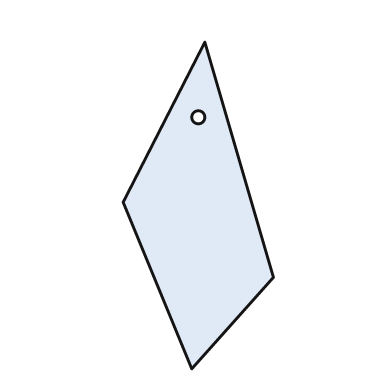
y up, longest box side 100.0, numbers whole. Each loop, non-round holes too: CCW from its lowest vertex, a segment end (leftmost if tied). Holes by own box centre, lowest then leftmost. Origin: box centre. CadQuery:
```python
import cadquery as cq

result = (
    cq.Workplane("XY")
    .moveTo(-2.0, -50.0)
    .lineTo(23.0, -22.0)
    .lineTo(2.0, 50.0)
    .lineTo(-23.0, 1.0)
    .close()
    .moveTo(0.0, 27.0)
    .circle(2.0)
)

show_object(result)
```